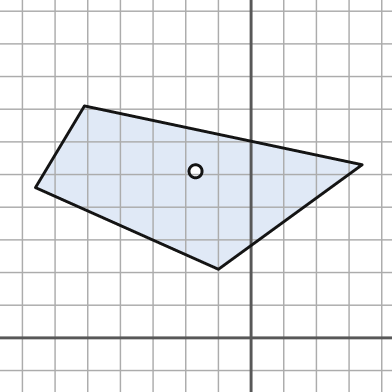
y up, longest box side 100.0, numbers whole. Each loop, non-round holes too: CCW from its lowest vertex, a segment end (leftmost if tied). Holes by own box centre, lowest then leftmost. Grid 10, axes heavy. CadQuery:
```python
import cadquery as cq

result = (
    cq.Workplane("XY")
    .moveTo(-10.0, 21.0)
    .lineTo(34.0, 53.0)
    .lineTo(-51.0, 71.0)
    .lineTo(-66.0, 46.0)
    .close()
    .moveTo(-17.0, 51.0)
    .circle(2.0)
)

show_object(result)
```